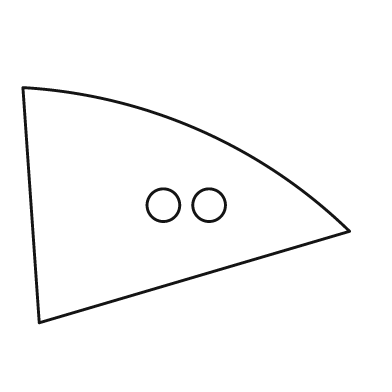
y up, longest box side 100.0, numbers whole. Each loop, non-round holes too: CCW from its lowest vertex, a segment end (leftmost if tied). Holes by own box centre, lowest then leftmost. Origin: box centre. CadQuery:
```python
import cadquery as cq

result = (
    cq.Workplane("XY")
    .moveTo(-45.0, -36.0)
    .lineTo(50.0, -8.0)
    .threePointArc((4.0, 23.0), (-50.0, 36.0))
    .close()
    .moveTo(-7.0, 0.0)
    .circle(5.0)
    .moveTo(7.0, 0.0)
    .circle(5.0)
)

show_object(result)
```